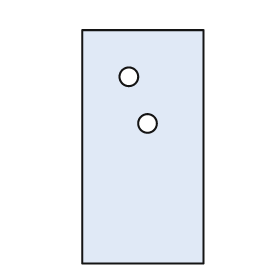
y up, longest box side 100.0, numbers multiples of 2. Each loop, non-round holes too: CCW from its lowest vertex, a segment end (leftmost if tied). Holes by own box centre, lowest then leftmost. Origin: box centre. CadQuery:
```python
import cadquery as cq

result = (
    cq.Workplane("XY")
    .moveTo(-26.0, -50.0)
    .lineTo(26.0, -50.0)
    .lineTo(26.0, 50.0)
    .lineTo(-26.0, 50.0)
    .close()
    .moveTo(2.0, 10.0)
    .circle(4.0)
    .moveTo(-6.0, 30.0)
    .circle(4.0)
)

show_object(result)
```